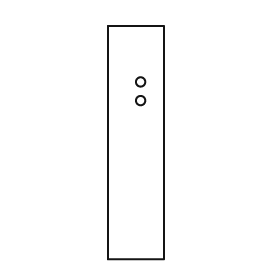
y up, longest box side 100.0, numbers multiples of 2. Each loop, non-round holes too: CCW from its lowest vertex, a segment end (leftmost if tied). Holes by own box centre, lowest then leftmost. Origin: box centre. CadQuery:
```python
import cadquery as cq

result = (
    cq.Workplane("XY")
    .moveTo(-12.0, -50.0)
    .lineTo(12.0, -50.0)
    .lineTo(12.0, 50.0)
    .lineTo(-12.0, 50.0)
    .close()
    .moveTo(2.0, 18.0)
    .circle(2.0)
    .moveTo(2.0, 26.0)
    .circle(2.0)
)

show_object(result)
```